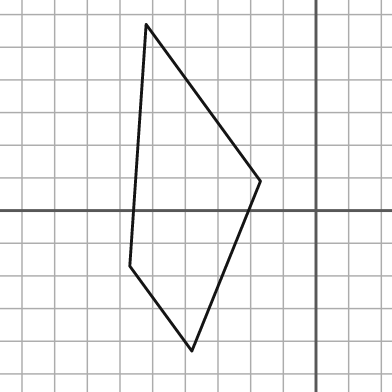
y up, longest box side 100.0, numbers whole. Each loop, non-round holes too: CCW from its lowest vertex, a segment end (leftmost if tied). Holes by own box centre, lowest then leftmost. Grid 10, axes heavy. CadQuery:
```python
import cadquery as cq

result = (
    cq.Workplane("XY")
    .moveTo(-38.0, -43.0)
    .lineTo(-17.0, 9.0)
    .lineTo(-52.0, 57.0)
    .lineTo(-57.0, -17.0)
    .close()
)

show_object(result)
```